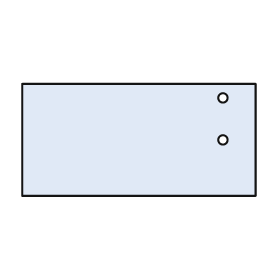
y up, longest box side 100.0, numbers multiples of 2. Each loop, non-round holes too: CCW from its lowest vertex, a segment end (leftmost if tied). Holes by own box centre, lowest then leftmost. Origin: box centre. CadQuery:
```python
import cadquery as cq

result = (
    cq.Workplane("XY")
    .moveTo(-50.0, -24.0)
    .lineTo(50.0, -24.0)
    .lineTo(50.0, 24.0)
    .lineTo(-50.0, 24.0)
    .close()
    .moveTo(36.0, 0.0)
    .circle(2.0)
    .moveTo(36.0, 18.0)
    .circle(2.0)
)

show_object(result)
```